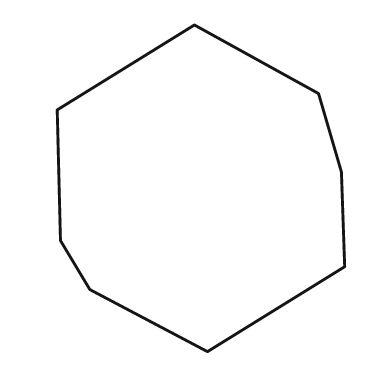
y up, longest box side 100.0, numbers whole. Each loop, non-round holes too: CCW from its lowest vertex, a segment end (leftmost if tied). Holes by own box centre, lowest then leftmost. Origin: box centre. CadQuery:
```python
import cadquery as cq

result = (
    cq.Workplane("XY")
    .moveTo(2.0, -50.0)
    .lineTo(44.0, -24.0)
    .lineTo(43.0, 5.0)
    .lineTo(36.0, 29.0)
    .lineTo(-2.0, 50.0)
    .lineTo(-44.0, 24.0)
    .lineTo(-43.0, -16.0)
    .lineTo(-34.0, -31.0)
    .close()
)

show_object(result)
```